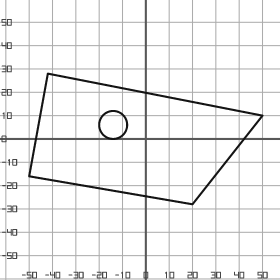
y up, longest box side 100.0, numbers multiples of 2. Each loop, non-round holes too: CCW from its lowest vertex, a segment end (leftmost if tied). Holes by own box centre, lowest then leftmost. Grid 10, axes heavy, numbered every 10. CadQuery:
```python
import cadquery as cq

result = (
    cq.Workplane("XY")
    .moveTo(20.0, -28.0)
    .lineTo(50.0, 10.0)
    .lineTo(-42.0, 28.0)
    .lineTo(-50.0, -16.0)
    .close()
    .moveTo(-14.0, 6.0)
    .circle(6.0)
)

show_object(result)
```